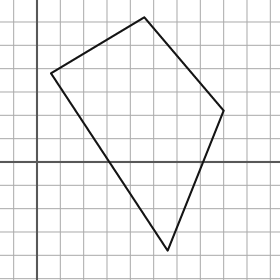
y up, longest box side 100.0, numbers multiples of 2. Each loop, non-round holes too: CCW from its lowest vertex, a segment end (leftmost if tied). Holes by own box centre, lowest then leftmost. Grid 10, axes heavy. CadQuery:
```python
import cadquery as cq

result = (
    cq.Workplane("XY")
    .moveTo(56.0, -38.0)
    .lineTo(80.0, 22.0)
    .lineTo(46.0, 62.0)
    .lineTo(6.0, 38.0)
    .close()
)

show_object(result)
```